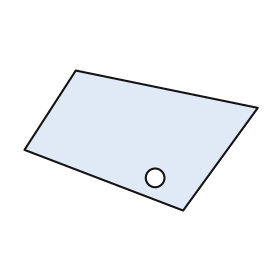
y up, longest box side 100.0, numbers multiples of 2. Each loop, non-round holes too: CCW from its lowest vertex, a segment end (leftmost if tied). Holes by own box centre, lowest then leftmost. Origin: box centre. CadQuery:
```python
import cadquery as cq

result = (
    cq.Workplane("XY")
    .moveTo(18.0, -30.0)
    .lineTo(50.0, 14.0)
    .lineTo(-28.0, 30.0)
    .lineTo(-50.0, -4.0)
    .close()
    .moveTo(6.0, -16.0)
    .circle(4.0)
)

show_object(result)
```